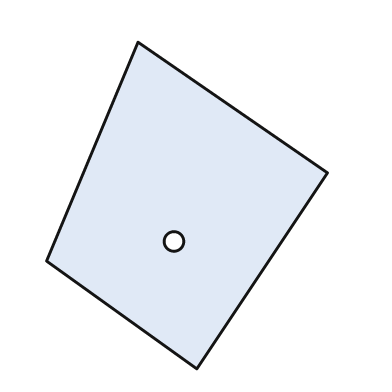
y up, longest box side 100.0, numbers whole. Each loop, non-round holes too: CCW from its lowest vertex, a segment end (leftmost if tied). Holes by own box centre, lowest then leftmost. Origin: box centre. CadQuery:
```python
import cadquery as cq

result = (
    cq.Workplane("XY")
    .moveTo(3.0, -50.0)
    .lineTo(43.0, 10.0)
    .lineTo(-15.0, 50.0)
    .lineTo(-43.0, -17.0)
    .close()
    .moveTo(-4.0, -11.0)
    .circle(3.0)
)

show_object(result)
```